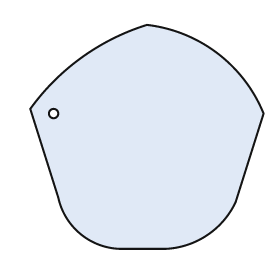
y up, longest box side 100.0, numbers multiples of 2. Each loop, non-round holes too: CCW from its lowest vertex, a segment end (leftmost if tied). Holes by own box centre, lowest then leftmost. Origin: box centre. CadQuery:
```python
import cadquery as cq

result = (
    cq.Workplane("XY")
    .moveTo(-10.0, -48.0)
    .lineTo(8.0, -48.0)
    .threePointArc((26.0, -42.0), (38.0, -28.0))
    .lineTo(50.0, 10.0)
    .threePointArc((30.0, 36.0), (0.0, 48.0))
    .threePointArc((-28.0, 34.0), (-50.0, 12.0))
    .lineTo(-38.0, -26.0)
    .threePointArc((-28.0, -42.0), (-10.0, -48.0))
    .close()
    .moveTo(-40.0, 10.0)
    .circle(2.0)
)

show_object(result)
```